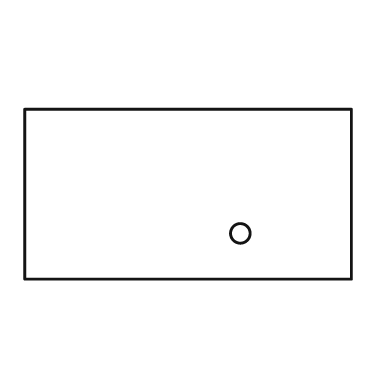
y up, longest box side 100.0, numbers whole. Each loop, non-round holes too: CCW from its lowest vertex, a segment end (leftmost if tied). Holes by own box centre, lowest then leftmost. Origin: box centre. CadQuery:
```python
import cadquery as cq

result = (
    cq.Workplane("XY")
    .moveTo(-50.0, -26.0)
    .lineTo(50.0, -26.0)
    .lineTo(50.0, 26.0)
    .lineTo(-50.0, 26.0)
    .close()
    .moveTo(16.0, -12.0)
    .circle(3.0)
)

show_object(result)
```